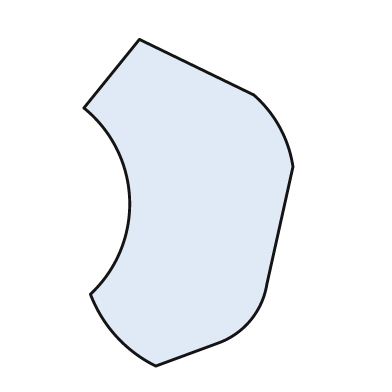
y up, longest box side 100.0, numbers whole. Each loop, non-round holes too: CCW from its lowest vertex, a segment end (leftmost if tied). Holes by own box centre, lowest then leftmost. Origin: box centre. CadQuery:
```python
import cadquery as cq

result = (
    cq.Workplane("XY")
    .moveTo(-10.0, -50.0)
    .lineTo(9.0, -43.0)
    .threePointArc((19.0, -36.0), (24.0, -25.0))
    .lineTo(32.0, 11.0)
    .threePointArc((28.0, 23.0), (20.0, 33.0))
    .lineTo(-15.0, 50.0)
    .lineTo(-32.0, 29.0)
    .threePointArc((-18.0, 1.0), (-30.0, -28.0))
    .threePointArc((-22.0, -41.0), (-10.0, -50.0))
    .close()
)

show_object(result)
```